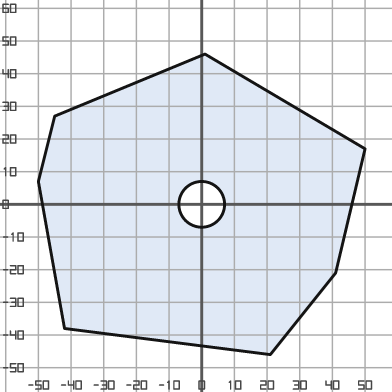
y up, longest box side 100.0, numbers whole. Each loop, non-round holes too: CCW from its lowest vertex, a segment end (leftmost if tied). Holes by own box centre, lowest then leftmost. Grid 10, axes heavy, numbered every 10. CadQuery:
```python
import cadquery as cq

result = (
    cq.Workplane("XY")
    .moveTo(21.0, -46.0)
    .lineTo(41.0, -21.0)
    .lineTo(50.0, 17.0)
    .lineTo(1.0, 46.0)
    .lineTo(-45.0, 27.0)
    .lineTo(-50.0, 7.0)
    .lineTo(-42.0, -38.0)
    .close()
    .moveTo(0.0, 0.0)
    .circle(7.0)
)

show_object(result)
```